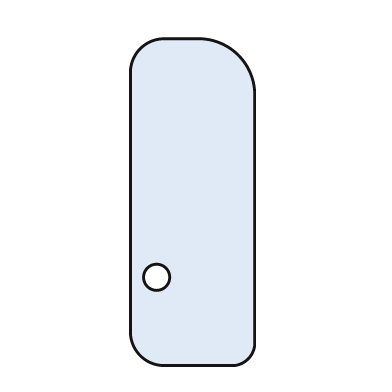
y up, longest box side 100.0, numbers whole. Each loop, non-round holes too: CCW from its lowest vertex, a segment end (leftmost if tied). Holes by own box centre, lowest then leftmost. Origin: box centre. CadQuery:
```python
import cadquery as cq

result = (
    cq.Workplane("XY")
    .moveTo(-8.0, -50.0)
    .lineTo(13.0, -50.0)
    .threePointArc((17.0, -48.0), (19.0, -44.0))
    .lineTo(19.0, 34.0)
    .threePointArc((14.0, 45.0), (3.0, 50.0))
    .lineTo(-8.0, 50.0)
    .threePointArc((-16.0, 47.0), (-19.0, 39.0))
    .lineTo(-19.0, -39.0)
    .threePointArc((-16.0, -47.0), (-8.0, -50.0))
    .close()
    .moveTo(-11.0, -23.0)
    .circle(4.0)
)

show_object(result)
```